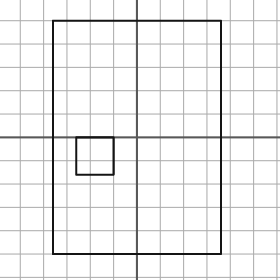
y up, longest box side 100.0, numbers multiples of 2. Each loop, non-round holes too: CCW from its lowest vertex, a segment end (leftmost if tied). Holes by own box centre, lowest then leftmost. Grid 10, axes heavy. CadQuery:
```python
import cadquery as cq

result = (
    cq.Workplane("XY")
    .moveTo(-36.0, -50.0)
    .lineTo(36.0, -50.0)
    .lineTo(36.0, 50.0)
    .lineTo(-36.0, 50.0)
    .close()
    .moveTo(-26.0, -16.0)
    .lineTo(-10.0, -16.0)
    .lineTo(-10.0, 0.0)
    .lineTo(-26.0, 0.0)
    .close()
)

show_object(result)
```